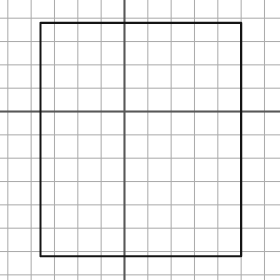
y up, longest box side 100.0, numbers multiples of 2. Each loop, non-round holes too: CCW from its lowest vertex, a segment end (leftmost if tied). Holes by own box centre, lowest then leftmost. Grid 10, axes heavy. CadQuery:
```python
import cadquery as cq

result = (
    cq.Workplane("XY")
    .moveTo(-36.0, -62.0)
    .lineTo(50.0, -62.0)
    .lineTo(50.0, 38.0)
    .lineTo(-36.0, 38.0)
    .close()
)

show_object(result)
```